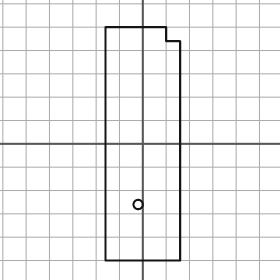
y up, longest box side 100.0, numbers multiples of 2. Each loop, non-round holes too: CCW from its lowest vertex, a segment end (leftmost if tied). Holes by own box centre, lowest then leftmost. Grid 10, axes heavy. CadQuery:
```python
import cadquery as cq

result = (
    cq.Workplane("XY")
    .moveTo(-16.0, -50.0)
    .lineTo(16.0, -50.0)
    .lineTo(16.0, 44.0)
    .lineTo(10.0, 44.0)
    .lineTo(10.0, 50.0)
    .lineTo(-16.0, 50.0)
    .close()
    .moveTo(-2.0, -26.0)
    .circle(2.0)
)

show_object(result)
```